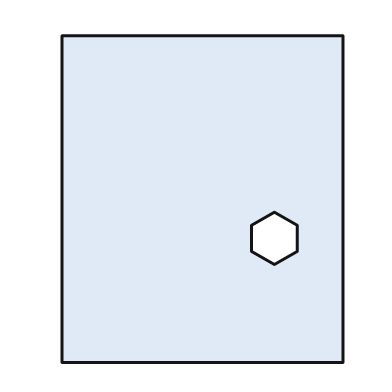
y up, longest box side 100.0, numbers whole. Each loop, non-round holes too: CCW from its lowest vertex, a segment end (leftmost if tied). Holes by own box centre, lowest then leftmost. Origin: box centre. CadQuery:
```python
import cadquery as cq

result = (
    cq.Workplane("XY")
    .moveTo(-43.0, -50.0)
    .lineTo(43.0, -50.0)
    .lineTo(43.0, 50.0)
    .lineTo(-43.0, 50.0)
    .close()
    .moveTo(22.0, -20.0)
    .lineTo(29.0, -16.0)
    .lineTo(29.0, -8.0)
    .lineTo(22.0, -4.0)
    .lineTo(15.0, -8.0)
    .lineTo(15.0, -16.0)
    .close()
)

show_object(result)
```